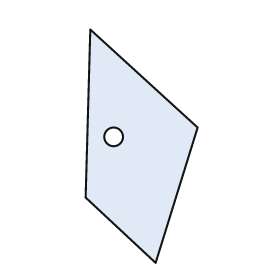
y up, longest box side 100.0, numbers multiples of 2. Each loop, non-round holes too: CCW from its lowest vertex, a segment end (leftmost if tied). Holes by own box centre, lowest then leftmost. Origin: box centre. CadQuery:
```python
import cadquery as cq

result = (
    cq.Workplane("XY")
    .moveTo(6.0, -50.0)
    .lineTo(24.0, 8.0)
    .lineTo(-22.0, 50.0)
    .lineTo(-24.0, -22.0)
    .close()
    .moveTo(-12.0, 4.0)
    .circle(4.0)
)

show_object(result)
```